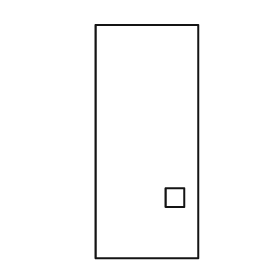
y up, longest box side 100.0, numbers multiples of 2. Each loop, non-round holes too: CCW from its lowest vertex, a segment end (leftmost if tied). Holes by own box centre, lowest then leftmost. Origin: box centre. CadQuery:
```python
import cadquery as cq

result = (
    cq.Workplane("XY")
    .moveTo(-22.0, -50.0)
    .lineTo(22.0, -50.0)
    .lineTo(22.0, 50.0)
    .lineTo(-22.0, 50.0)
    .close()
    .moveTo(8.0, -28.0)
    .lineTo(16.0, -28.0)
    .lineTo(16.0, -20.0)
    .lineTo(8.0, -20.0)
    .close()
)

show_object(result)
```